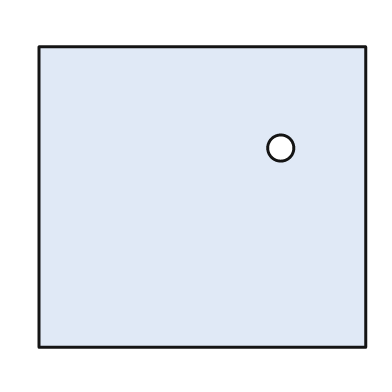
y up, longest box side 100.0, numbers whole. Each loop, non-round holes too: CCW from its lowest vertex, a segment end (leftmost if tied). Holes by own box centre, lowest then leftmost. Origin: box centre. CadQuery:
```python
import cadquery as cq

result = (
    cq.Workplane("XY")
    .moveTo(-50.0, -46.0)
    .lineTo(50.0, -46.0)
    .lineTo(50.0, 46.0)
    .lineTo(-50.0, 46.0)
    .close()
    .moveTo(24.0, 15.0)
    .circle(4.0)
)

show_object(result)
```